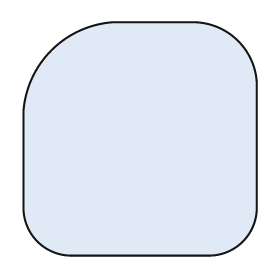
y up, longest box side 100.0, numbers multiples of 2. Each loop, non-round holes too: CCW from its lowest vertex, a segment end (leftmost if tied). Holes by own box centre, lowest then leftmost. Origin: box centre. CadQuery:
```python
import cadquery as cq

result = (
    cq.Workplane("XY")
    .moveTo(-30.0, -50.0)
    .lineTo(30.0, -50.0)
    .threePointArc((44.0, -44.0), (50.0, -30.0))
    .lineTo(50.0, 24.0)
    .threePointArc((42.0, 42.0), (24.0, 50.0))
    .lineTo(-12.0, 50.0)
    .threePointArc((-38.0, 38.0), (-50.0, 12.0))
    .lineTo(-50.0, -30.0)
    .threePointArc((-44.0, -44.0), (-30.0, -50.0))
    .close()
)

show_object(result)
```